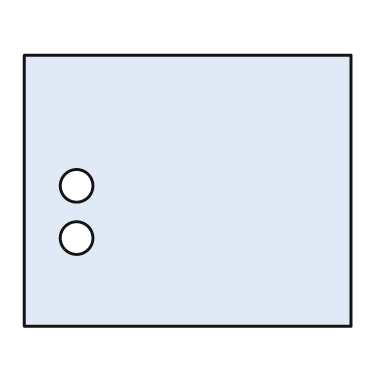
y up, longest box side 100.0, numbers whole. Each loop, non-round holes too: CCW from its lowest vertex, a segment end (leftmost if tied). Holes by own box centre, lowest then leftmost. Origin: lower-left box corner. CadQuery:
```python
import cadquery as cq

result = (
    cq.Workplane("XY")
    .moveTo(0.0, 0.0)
    .lineTo(100.0, 0.0)
    .lineTo(100.0, 83.0)
    .lineTo(0.0, 83.0)
    .close()
    .moveTo(16.0, 27.0)
    .circle(5.0)
    .moveTo(16.0, 43.0)
    .circle(5.0)
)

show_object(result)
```